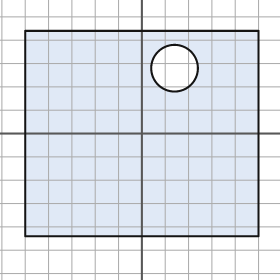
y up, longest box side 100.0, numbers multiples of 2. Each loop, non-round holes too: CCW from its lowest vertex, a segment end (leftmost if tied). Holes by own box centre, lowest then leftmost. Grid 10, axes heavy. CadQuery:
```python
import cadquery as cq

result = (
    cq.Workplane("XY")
    .moveTo(-50.0, -44.0)
    .lineTo(50.0, -44.0)
    .lineTo(50.0, 44.0)
    .lineTo(-50.0, 44.0)
    .close()
    .moveTo(14.0, 28.0)
    .circle(10.0)
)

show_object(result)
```